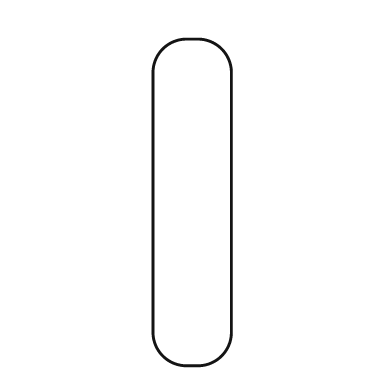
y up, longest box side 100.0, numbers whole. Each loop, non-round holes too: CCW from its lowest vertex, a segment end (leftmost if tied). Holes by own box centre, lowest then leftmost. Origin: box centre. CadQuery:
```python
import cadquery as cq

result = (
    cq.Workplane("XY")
    .moveTo(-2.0, -50.0)
    .lineTo(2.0, -50.0)
    .threePointArc((9.0, -47.0), (12.0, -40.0))
    .lineTo(12.0, 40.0)
    .threePointArc((9.0, 47.0), (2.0, 50.0))
    .lineTo(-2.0, 50.0)
    .threePointArc((-9.0, 47.0), (-12.0, 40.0))
    .lineTo(-12.0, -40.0)
    .threePointArc((-9.0, -47.0), (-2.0, -50.0))
    .close()
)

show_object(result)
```